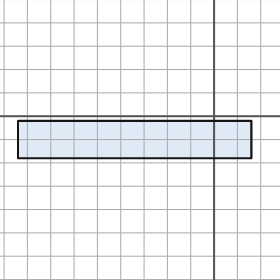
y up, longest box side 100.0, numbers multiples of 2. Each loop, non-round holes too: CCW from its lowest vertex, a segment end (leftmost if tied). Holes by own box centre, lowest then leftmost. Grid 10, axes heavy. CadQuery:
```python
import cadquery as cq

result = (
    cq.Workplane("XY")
    .moveTo(-84.0, -18.0)
    .lineTo(16.0, -18.0)
    .lineTo(16.0, -2.0)
    .lineTo(-84.0, -2.0)
    .close()
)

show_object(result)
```